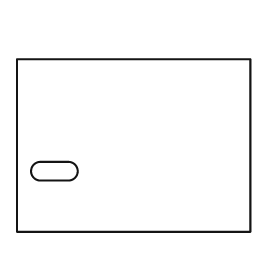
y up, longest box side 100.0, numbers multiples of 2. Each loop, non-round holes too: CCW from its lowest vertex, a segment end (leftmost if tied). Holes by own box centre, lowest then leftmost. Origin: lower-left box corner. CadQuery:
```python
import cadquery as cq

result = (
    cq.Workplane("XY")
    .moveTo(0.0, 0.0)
    .lineTo(100.0, 0.0)
    .lineTo(100.0, 74.0)
    .lineTo(0.0, 74.0)
    .close()
    .moveTo(10.0, 22.0)
    .lineTo(22.0, 22.0)
    .threePointArc((26.0, 26.0), (22.0, 30.0))
    .lineTo(10.0, 30.0)
    .threePointArc((6.0, 26.0), (10.0, 22.0))
    .close()
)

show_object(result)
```